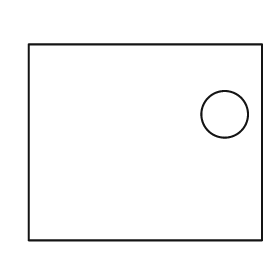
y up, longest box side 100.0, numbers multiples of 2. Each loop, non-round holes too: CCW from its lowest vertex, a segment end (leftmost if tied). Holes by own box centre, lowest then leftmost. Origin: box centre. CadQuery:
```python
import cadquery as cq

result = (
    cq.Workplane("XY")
    .moveTo(-50.0, -42.0)
    .lineTo(50.0, -42.0)
    .lineTo(50.0, 42.0)
    .lineTo(-50.0, 42.0)
    .close()
    .moveTo(34.0, 12.0)
    .circle(10.0)
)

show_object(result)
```